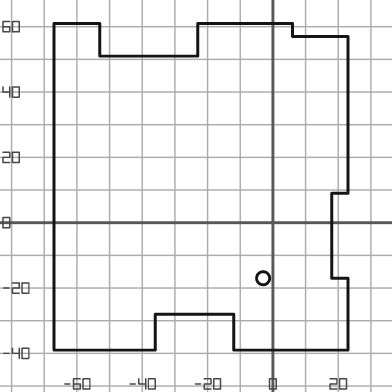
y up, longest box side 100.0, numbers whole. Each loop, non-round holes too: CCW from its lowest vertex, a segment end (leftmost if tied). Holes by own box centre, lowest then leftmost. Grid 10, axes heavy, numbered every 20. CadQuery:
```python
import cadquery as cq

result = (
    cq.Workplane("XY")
    .moveTo(-67.0, -39.0)
    .lineTo(-36.0, -39.0)
    .lineTo(-36.0, -28.0)
    .lineTo(-12.0, -28.0)
    .lineTo(-12.0, -39.0)
    .lineTo(23.0, -39.0)
    .lineTo(23.0, -17.0)
    .lineTo(18.0, -17.0)
    .lineTo(18.0, 9.0)
    .lineTo(23.0, 9.0)
    .lineTo(23.0, 57.0)
    .lineTo(6.0, 57.0)
    .lineTo(6.0, 61.0)
    .lineTo(-23.0, 61.0)
    .lineTo(-23.0, 51.0)
    .lineTo(-53.0, 51.0)
    .lineTo(-53.0, 61.0)
    .lineTo(-67.0, 61.0)
    .close()
    .moveTo(-3.0, -17.0)
    .circle(2.0)
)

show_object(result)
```